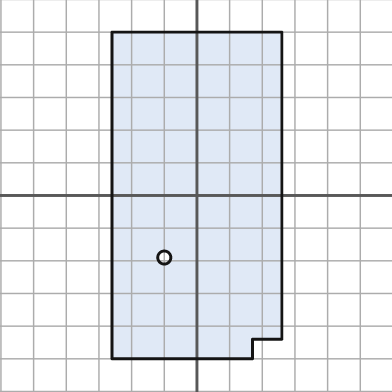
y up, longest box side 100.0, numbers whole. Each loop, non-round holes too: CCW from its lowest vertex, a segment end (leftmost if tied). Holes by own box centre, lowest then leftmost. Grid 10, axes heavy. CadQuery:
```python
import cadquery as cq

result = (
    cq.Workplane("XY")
    .moveTo(-26.0, -50.0)
    .lineTo(17.0, -50.0)
    .lineTo(17.0, -44.0)
    .lineTo(26.0, -44.0)
    .lineTo(26.0, 50.0)
    .lineTo(-26.0, 50.0)
    .close()
    .moveTo(-10.0, -19.0)
    .circle(2.0)
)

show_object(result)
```